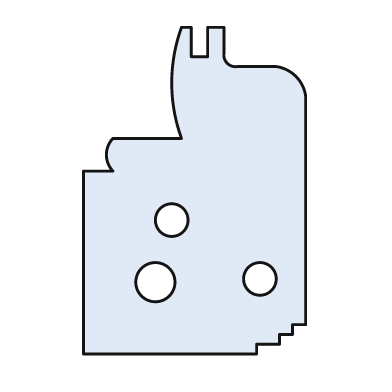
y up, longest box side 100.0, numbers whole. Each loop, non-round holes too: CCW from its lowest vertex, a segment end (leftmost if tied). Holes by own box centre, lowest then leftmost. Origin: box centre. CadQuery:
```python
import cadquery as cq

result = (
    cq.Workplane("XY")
    .moveTo(-34.0, -50.0)
    .lineTo(19.0, -50.0)
    .lineTo(19.0, -47.0)
    .lineTo(26.0, -47.0)
    .lineTo(26.0, -44.0)
    .lineTo(30.0, -44.0)
    .lineTo(30.0, -41.0)
    .lineTo(34.0, -41.0)
    .lineTo(34.0, 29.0)
    .threePointArc((31.0, 35.0), (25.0, 38.0))
    .lineTo(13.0, 38.0)
    .threePointArc((10.0, 39.0), (9.0, 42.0))
    .lineTo(9.0, 50.0)
    .lineTo(4.0, 50.0)
    .lineTo(4.0, 41.0)
    .lineTo(-1.0, 41.0)
    .lineTo(-1.0, 50.0)
    .lineTo(-4.0, 50.0)
    .threePointArc((-7.0, 33.0), (-4.0, 16.0))
    .lineTo(-25.0, 16.0)
    .threePointArc((-27.0, 11.0), (-25.0, 6.0))
    .lineTo(-34.0, 6.0)
    .close()
    .moveTo(-12.0, -28.0)
    .circle(6.0)
    .moveTo(20.0, -27.0)
    .circle(5.0)
    .moveTo(-7.0, -9.0)
    .circle(5.0)
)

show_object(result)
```